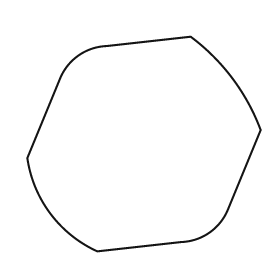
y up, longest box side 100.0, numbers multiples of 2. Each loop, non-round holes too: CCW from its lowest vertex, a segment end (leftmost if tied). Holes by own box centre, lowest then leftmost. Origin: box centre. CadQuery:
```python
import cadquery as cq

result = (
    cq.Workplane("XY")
    .moveTo(-20.0, -46.0)
    .lineTo(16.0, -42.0)
    .threePointArc((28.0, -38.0), (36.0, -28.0))
    .lineTo(50.0, 6.0)
    .threePointArc((38.0, 28.0), (20.0, 46.0))
    .lineTo(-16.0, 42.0)
    .threePointArc((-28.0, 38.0), (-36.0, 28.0))
    .lineTo(-50.0, -6.0)
    .threePointArc((-40.0, -30.0), (-20.0, -46.0))
    .close()
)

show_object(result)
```